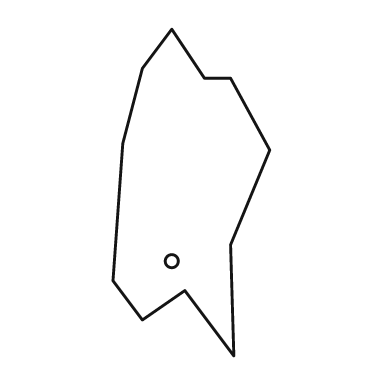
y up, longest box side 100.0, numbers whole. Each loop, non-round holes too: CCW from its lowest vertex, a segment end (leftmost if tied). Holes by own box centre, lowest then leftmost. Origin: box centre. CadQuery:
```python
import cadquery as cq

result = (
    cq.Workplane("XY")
    .moveTo(13.0, -50.0)
    .lineTo(12.0, -16.0)
    .lineTo(24.0, 13.0)
    .lineTo(12.0, 35.0)
    .lineTo(4.0, 35.0)
    .lineTo(-6.0, 50.0)
    .lineTo(-15.0, 38.0)
    .lineTo(-21.0, 15.0)
    .lineTo(-24.0, -27.0)
    .lineTo(-15.0, -39.0)
    .lineTo(-2.0, -30.0)
    .close()
    .moveTo(-6.0, -21.0)
    .circle(2.0)
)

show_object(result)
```